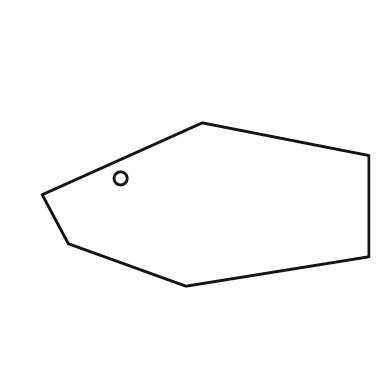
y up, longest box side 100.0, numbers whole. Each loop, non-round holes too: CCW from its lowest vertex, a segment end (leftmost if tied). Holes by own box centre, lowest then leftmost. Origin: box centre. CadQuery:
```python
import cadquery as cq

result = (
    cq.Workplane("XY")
    .moveTo(-6.0, -25.0)
    .lineTo(50.0, -16.0)
    .lineTo(50.0, 15.0)
    .lineTo(-1.0, 25.0)
    .lineTo(-50.0, 3.0)
    .lineTo(-42.0, -12.0)
    .close()
    .moveTo(-26.0, 8.0)
    .circle(2.0)
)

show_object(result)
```